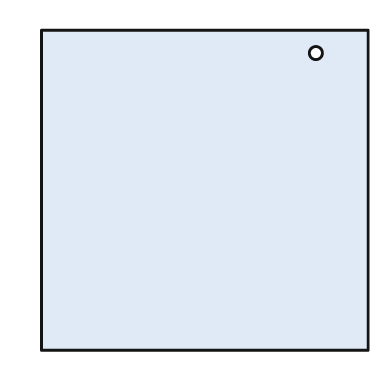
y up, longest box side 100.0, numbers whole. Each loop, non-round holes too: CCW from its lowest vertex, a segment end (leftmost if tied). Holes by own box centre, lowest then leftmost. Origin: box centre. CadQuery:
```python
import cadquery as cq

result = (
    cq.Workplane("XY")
    .moveTo(-50.0, -49.0)
    .lineTo(50.0, -49.0)
    .lineTo(50.0, 49.0)
    .lineTo(-50.0, 49.0)
    .close()
    .moveTo(34.0, 42.0)
    .circle(2.0)
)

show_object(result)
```